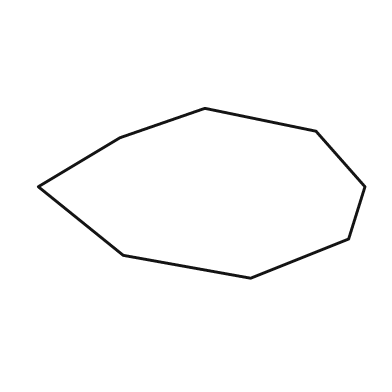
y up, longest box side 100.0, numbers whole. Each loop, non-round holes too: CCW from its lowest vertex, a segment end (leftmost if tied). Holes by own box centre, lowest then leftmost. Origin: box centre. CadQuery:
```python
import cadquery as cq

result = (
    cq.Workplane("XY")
    .moveTo(15.0, -26.0)
    .lineTo(45.0, -14.0)
    .lineTo(50.0, 2.0)
    .lineTo(35.0, 19.0)
    .lineTo(1.0, 26.0)
    .lineTo(-25.0, 17.0)
    .lineTo(-50.0, 2.0)
    .lineTo(-24.0, -19.0)
    .close()
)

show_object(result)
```